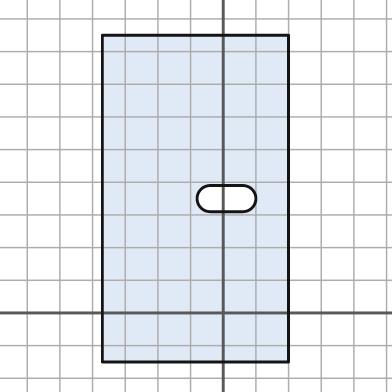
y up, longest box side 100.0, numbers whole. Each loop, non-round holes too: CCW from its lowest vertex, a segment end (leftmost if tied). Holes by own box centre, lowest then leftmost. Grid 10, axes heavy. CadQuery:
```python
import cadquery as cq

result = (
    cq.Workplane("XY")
    .moveTo(-37.0, -15.0)
    .lineTo(20.0, -15.0)
    .lineTo(20.0, 85.0)
    .lineTo(-37.0, 85.0)
    .close()
    .moveTo(-4.0, 31.0)
    .lineTo(6.0, 31.0)
    .threePointArc((10.0, 35.0), (6.0, 39.0))
    .lineTo(-4.0, 39.0)
    .threePointArc((-8.0, 35.0), (-4.0, 31.0))
    .close()
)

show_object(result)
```